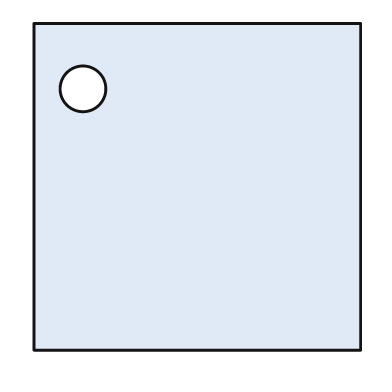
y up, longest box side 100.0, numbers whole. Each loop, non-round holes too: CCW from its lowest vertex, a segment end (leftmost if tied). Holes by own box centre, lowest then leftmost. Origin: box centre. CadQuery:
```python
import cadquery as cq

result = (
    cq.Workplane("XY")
    .moveTo(-50.0, -50.0)
    .lineTo(50.0, -50.0)
    .lineTo(50.0, 50.0)
    .lineTo(-50.0, 50.0)
    .close()
    .moveTo(-35.0, 30.0)
    .circle(7.0)
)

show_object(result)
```